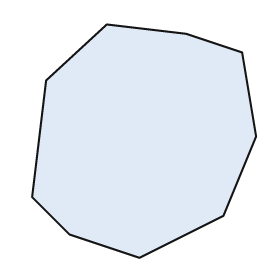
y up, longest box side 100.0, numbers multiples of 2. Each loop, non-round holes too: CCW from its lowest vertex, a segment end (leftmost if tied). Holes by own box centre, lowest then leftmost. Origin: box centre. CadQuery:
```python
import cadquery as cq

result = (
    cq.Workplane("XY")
    .moveTo(-2.0, -50.0)
    .lineTo(34.0, -32.0)
    .lineTo(48.0, 2.0)
    .lineTo(42.0, 38.0)
    .lineTo(18.0, 46.0)
    .lineTo(-16.0, 50.0)
    .lineTo(-42.0, 26.0)
    .lineTo(-48.0, -24.0)
    .lineTo(-32.0, -40.0)
    .close()
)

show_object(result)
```